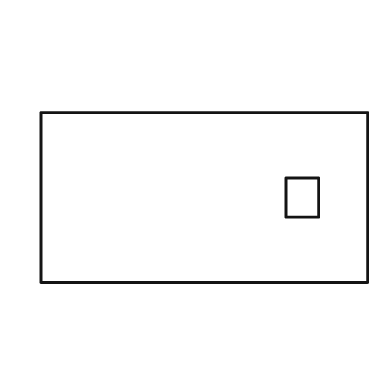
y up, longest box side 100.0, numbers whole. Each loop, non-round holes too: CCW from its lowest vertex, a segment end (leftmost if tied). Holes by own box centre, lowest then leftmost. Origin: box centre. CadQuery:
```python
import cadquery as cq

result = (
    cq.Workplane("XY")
    .moveTo(-50.0, -26.0)
    .lineTo(50.0, -26.0)
    .lineTo(50.0, 26.0)
    .lineTo(-50.0, 26.0)
    .close()
    .moveTo(25.0, -6.0)
    .lineTo(35.0, -6.0)
    .lineTo(35.0, 6.0)
    .lineTo(25.0, 6.0)
    .close()
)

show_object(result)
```